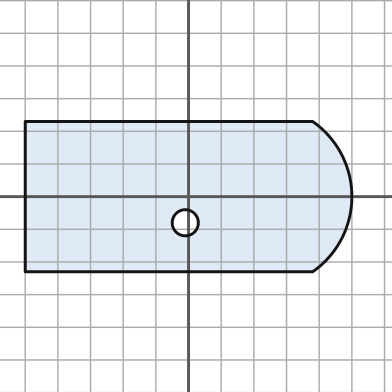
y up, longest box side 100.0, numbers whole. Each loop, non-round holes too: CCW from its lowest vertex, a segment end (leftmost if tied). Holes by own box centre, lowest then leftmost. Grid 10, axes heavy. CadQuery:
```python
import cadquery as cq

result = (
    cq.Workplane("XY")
    .moveTo(-50.0, -23.0)
    .lineTo(38.0, -23.0)
    .threePointArc((50.0, 0.0), (38.0, 23.0))
    .lineTo(-50.0, 23.0)
    .close()
    .moveTo(-1.0, -8.0)
    .circle(4.0)
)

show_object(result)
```